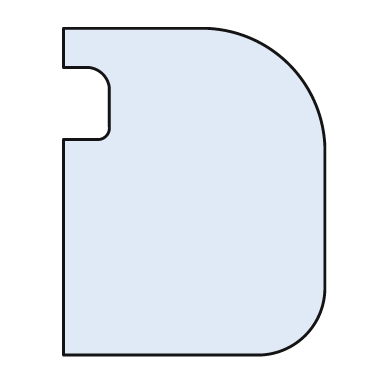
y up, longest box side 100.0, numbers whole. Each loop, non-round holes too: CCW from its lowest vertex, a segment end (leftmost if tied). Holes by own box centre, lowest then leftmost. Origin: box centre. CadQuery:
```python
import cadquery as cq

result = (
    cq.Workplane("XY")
    .moveTo(-40.0, -50.0)
    .lineTo(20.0, -50.0)
    .threePointArc((34.0, -44.0), (40.0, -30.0))
    .lineTo(40.0, 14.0)
    .threePointArc((29.0, 39.0), (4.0, 50.0))
    .lineTo(-40.0, 50.0)
    .lineTo(-40.0, 38.0)
    .lineTo(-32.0, 38.0)
    .threePointArc((-28.0, 36.0), (-26.0, 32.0))
    .lineTo(-26.0, 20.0)
    .threePointArc((-27.0, 17.0), (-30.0, 16.0))
    .lineTo(-40.0, 16.0)
    .close()
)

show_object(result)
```